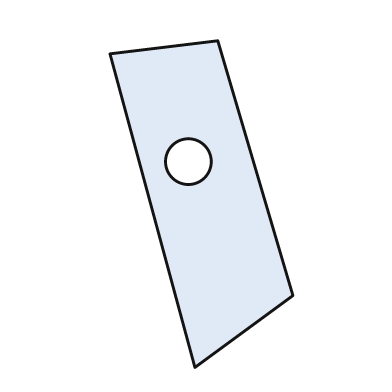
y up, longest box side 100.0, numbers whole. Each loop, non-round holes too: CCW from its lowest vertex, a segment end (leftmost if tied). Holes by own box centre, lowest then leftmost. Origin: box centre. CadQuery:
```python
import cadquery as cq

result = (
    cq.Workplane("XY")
    .moveTo(-2.0, -50.0)
    .lineTo(28.0, -28.0)
    .lineTo(5.0, 50.0)
    .lineTo(-28.0, 46.0)
    .close()
    .moveTo(-4.0, 13.0)
    .circle(7.0)
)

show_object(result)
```